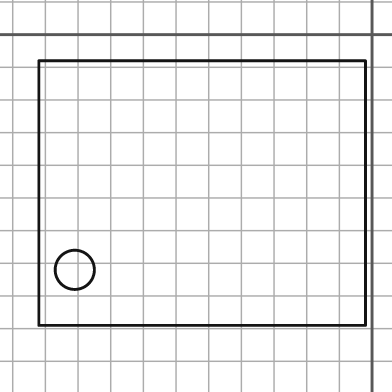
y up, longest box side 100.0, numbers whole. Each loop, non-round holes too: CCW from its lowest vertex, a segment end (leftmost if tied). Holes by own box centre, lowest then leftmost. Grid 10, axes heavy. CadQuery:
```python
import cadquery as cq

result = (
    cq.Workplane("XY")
    .moveTo(-102.0, -89.0)
    .lineTo(-2.0, -89.0)
    .lineTo(-2.0, -8.0)
    .lineTo(-102.0, -8.0)
    .close()
    .moveTo(-91.0, -72.0)
    .circle(6.0)
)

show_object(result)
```